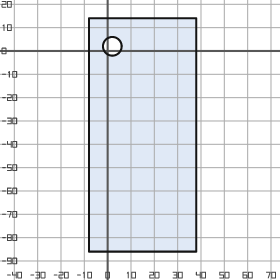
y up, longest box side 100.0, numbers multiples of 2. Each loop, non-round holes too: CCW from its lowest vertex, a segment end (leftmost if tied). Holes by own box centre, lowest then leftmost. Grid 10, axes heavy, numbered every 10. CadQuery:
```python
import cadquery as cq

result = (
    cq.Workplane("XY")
    .moveTo(-8.0, -86.0)
    .lineTo(38.0, -86.0)
    .lineTo(38.0, 14.0)
    .lineTo(-8.0, 14.0)
    .close()
    .moveTo(2.0, 2.0)
    .circle(4.0)
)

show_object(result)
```